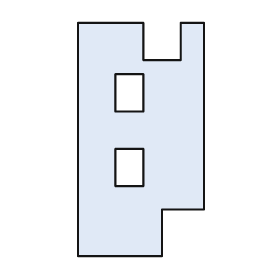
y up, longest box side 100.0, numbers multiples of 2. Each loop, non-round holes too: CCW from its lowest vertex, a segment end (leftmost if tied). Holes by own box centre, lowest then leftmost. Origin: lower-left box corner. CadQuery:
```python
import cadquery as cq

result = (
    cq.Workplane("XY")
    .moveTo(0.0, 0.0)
    .lineTo(36.0, 0.0)
    .lineTo(36.0, 20.0)
    .lineTo(54.0, 20.0)
    .lineTo(54.0, 100.0)
    .lineTo(44.0, 100.0)
    .lineTo(44.0, 84.0)
    .lineTo(28.0, 84.0)
    .lineTo(28.0, 100.0)
    .lineTo(0.0, 100.0)
    .close()
    .moveTo(16.0, 30.0)
    .lineTo(28.0, 30.0)
    .lineTo(28.0, 46.0)
    .lineTo(16.0, 46.0)
    .close()
    .moveTo(16.0, 62.0)
    .lineTo(28.0, 62.0)
    .lineTo(28.0, 78.0)
    .lineTo(16.0, 78.0)
    .close()
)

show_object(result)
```